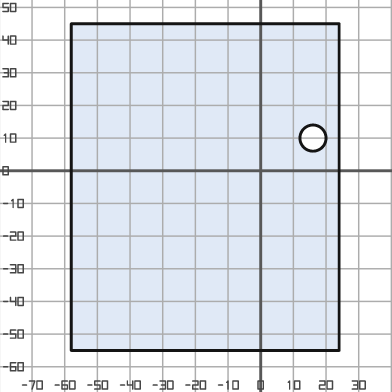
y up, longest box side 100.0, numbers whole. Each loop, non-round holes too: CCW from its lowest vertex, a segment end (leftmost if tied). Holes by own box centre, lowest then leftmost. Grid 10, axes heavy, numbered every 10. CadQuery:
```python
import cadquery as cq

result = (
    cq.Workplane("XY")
    .moveTo(-58.0, -55.0)
    .lineTo(24.0, -55.0)
    .lineTo(24.0, 45.0)
    .lineTo(-58.0, 45.0)
    .close()
    .moveTo(16.0, 10.0)
    .circle(4.0)
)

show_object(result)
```